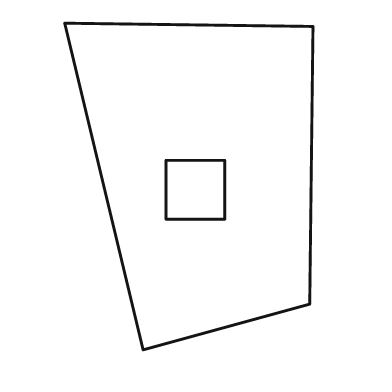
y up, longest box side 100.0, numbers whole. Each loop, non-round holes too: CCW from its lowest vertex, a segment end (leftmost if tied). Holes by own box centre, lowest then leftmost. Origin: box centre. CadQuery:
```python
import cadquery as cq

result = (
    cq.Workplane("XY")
    .moveTo(-14.0, -50.0)
    .lineTo(37.0, -36.0)
    .lineTo(38.0, 49.0)
    .lineTo(-38.0, 50.0)
    .close()
    .moveTo(-7.0, -10.0)
    .lineTo(11.0, -10.0)
    .lineTo(11.0, 8.0)
    .lineTo(-7.0, 8.0)
    .close()
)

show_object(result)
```